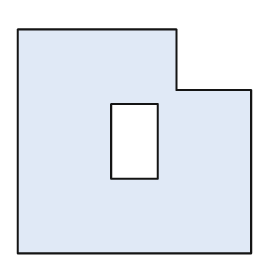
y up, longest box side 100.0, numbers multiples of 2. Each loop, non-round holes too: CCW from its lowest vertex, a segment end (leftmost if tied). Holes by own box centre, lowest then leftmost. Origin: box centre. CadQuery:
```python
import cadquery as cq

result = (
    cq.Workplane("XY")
    .moveTo(-50.0, -48.0)
    .lineTo(50.0, -48.0)
    .lineTo(50.0, 22.0)
    .lineTo(18.0, 22.0)
    .lineTo(18.0, 48.0)
    .lineTo(-50.0, 48.0)
    .close()
    .moveTo(-10.0, -16.0)
    .lineTo(10.0, -16.0)
    .lineTo(10.0, 16.0)
    .lineTo(-10.0, 16.0)
    .close()
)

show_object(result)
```